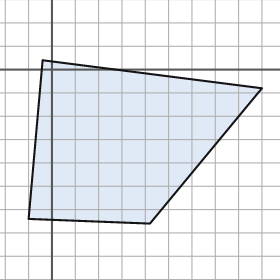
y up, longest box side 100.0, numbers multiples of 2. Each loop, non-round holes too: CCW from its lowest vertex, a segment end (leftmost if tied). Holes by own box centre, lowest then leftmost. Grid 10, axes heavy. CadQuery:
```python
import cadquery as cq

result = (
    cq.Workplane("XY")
    .moveTo(42.0, -66.0)
    .lineTo(90.0, -8.0)
    .lineTo(-4.0, 4.0)
    .lineTo(-10.0, -64.0)
    .close()
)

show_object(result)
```